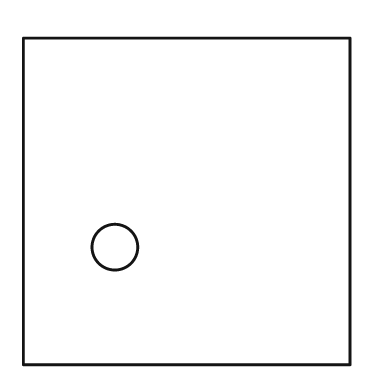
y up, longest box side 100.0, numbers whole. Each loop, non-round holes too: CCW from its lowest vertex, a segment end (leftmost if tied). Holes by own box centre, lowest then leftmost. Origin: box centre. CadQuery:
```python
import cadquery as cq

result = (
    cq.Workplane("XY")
    .moveTo(-50.0, -50.0)
    .lineTo(50.0, -50.0)
    .lineTo(50.0, 50.0)
    .lineTo(-50.0, 50.0)
    .close()
    .moveTo(-22.0, -14.0)
    .circle(7.0)
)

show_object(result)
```